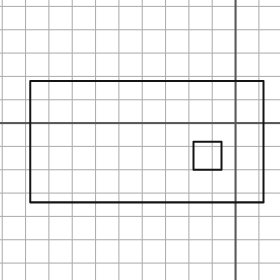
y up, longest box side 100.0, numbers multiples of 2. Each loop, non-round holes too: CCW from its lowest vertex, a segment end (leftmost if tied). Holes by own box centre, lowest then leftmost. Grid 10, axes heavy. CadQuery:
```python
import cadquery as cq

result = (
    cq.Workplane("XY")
    .moveTo(-88.0, -34.0)
    .lineTo(12.0, -34.0)
    .lineTo(12.0, 18.0)
    .lineTo(-88.0, 18.0)
    .close()
    .moveTo(-18.0, -20.0)
    .lineTo(-6.0, -20.0)
    .lineTo(-6.0, -8.0)
    .lineTo(-18.0, -8.0)
    .close()
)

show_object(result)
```